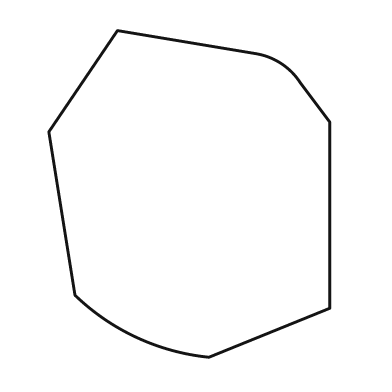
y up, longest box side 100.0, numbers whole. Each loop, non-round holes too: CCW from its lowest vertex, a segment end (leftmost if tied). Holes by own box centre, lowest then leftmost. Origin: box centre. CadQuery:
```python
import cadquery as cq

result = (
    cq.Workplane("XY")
    .moveTo(6.0, -50.0)
    .lineTo(43.0, -35.0)
    .lineTo(43.0, 22.0)
    .lineTo(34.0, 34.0)
    .threePointArc((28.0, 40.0), (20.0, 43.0))
    .lineTo(-22.0, 50.0)
    .lineTo(-43.0, 19.0)
    .lineTo(-35.0, -31.0)
    .threePointArc((-16.0, -44.0), (6.0, -50.0))
    .close()
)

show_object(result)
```